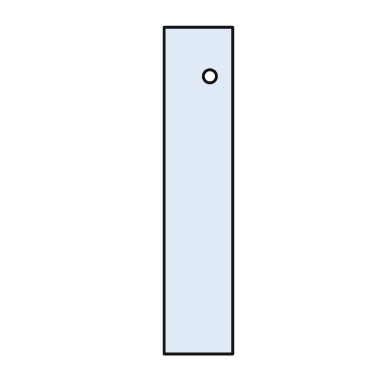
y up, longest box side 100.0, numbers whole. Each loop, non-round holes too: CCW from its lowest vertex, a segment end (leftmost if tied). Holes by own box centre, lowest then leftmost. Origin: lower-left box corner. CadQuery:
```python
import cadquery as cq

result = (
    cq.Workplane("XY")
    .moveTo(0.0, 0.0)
    .lineTo(21.0, 0.0)
    .lineTo(21.0, 100.0)
    .lineTo(0.0, 100.0)
    .close()
    .moveTo(14.0, 85.0)
    .circle(2.0)
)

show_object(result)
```